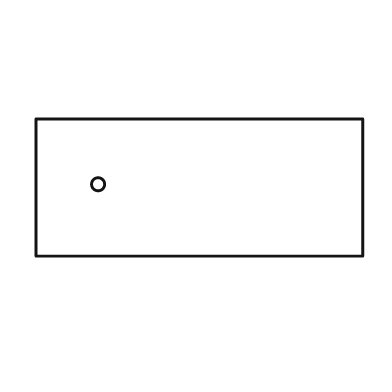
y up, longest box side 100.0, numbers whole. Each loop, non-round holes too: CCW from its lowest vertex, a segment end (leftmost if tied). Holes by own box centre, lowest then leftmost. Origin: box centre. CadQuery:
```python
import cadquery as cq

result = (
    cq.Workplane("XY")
    .moveTo(-50.0, -21.0)
    .lineTo(50.0, -21.0)
    .lineTo(50.0, 21.0)
    .lineTo(-50.0, 21.0)
    .close()
    .moveTo(-31.0, 1.0)
    .circle(2.0)
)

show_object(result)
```